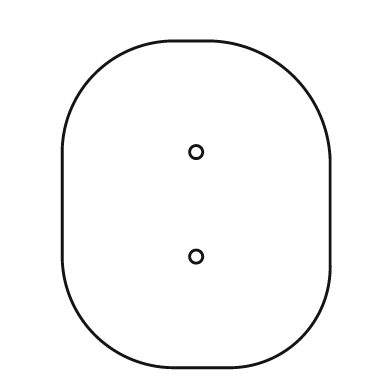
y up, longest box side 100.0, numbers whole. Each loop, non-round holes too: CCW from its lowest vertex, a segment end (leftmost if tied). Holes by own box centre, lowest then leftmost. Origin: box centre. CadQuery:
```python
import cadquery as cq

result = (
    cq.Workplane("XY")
    .moveTo(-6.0, -50.0)
    .lineTo(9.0, -50.0)
    .threePointArc((32.0, -41.0), (41.0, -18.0))
    .lineTo(41.0, 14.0)
    .threePointArc((30.0, 39.0), (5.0, 50.0))
    .lineTo(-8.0, 50.0)
    .threePointArc((-31.0, 40.0), (-41.0, 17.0))
    .lineTo(-41.0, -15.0)
    .threePointArc((-31.0, -40.0), (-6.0, -50.0))
    .close()
    .moveTo(0.0, -16.0)
    .circle(2.0)
    .moveTo(0.0, 16.0)
    .circle(2.0)
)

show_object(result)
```